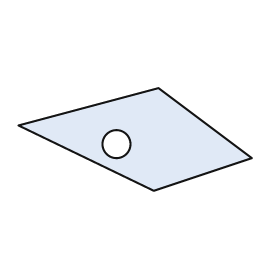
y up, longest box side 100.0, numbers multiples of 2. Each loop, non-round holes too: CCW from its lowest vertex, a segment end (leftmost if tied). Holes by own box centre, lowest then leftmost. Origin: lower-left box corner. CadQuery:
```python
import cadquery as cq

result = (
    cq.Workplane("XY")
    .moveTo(58.0, 0.0)
    .lineTo(100.0, 14.0)
    .lineTo(60.0, 44.0)
    .lineTo(0.0, 28.0)
    .close()
    .moveTo(42.0, 20.0)
    .circle(6.0)
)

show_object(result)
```